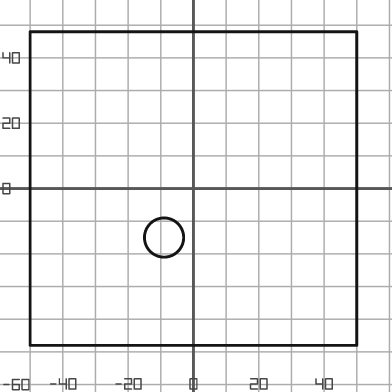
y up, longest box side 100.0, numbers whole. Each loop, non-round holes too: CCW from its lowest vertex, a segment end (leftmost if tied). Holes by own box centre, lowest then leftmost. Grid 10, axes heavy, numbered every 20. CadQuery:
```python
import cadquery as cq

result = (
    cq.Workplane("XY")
    .moveTo(-50.0, -48.0)
    .lineTo(50.0, -48.0)
    .lineTo(50.0, 48.0)
    .lineTo(-50.0, 48.0)
    .close()
    .moveTo(-9.0, -15.0)
    .circle(6.0)
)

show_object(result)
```